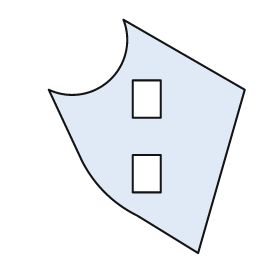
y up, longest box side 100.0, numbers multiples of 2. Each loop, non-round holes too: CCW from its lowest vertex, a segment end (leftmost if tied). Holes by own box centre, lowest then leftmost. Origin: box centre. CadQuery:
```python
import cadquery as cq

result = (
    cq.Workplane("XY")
    .moveTo(22.0, -50.0)
    .lineTo(42.0, 20.0)
    .lineTo(-10.0, 50.0)
    .threePointArc((-16.0, 24.0), (-42.0, 20.0))
    .lineTo(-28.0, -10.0)
    .threePointArc((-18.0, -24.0), (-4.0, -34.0))
    .close()
    .moveTo(-6.0, -24.0)
    .lineTo(6.0, -24.0)
    .lineTo(6.0, -8.0)
    .lineTo(-6.0, -8.0)
    .close()
    .moveTo(-6.0, 8.0)
    .lineTo(6.0, 8.0)
    .lineTo(6.0, 24.0)
    .lineTo(-6.0, 24.0)
    .close()
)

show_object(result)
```